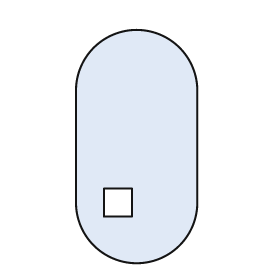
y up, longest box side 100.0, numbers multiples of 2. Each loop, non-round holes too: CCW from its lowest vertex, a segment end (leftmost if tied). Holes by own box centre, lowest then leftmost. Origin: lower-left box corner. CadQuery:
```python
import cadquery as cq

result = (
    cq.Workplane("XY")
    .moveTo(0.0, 26.0)
    .threePointArc((26.0, 0.0), (52.0, 26.0))
    .lineTo(52.0, 74.0)
    .threePointArc((26.0, 100.0), (0.0, 74.0))
    .close()
    .moveTo(12.0, 20.0)
    .lineTo(24.0, 20.0)
    .lineTo(24.0, 32.0)
    .lineTo(12.0, 32.0)
    .close()
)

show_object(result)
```